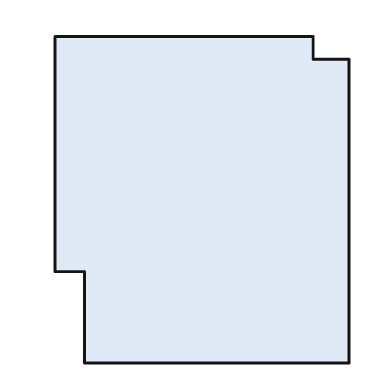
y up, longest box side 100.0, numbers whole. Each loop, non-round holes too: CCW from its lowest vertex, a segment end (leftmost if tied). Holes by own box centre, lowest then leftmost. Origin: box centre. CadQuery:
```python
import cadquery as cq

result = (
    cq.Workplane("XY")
    .moveTo(-36.0, -50.0)
    .lineTo(45.0, -50.0)
    .lineTo(45.0, 43.0)
    .lineTo(34.0, 43.0)
    .lineTo(34.0, 50.0)
    .lineTo(-45.0, 50.0)
    .lineTo(-45.0, -22.0)
    .lineTo(-36.0, -22.0)
    .close()
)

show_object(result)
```